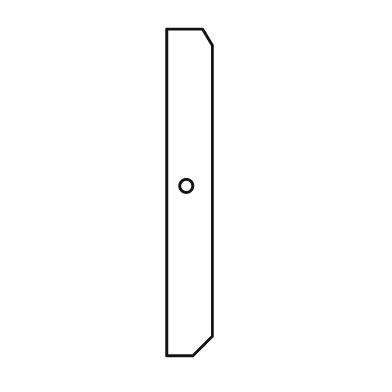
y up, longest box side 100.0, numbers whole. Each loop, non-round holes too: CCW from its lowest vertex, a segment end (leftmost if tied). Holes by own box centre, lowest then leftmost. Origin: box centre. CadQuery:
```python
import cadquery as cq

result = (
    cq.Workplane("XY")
    .moveTo(-7.0, -50.0)
    .lineTo(1.0, -50.0)
    .lineTo(7.0, -44.0)
    .lineTo(7.0, 45.0)
    .lineTo(4.0, 50.0)
    .lineTo(-7.0, 50.0)
    .close()
    .moveTo(-1.0, 2.0)
    .circle(2.0)
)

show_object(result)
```